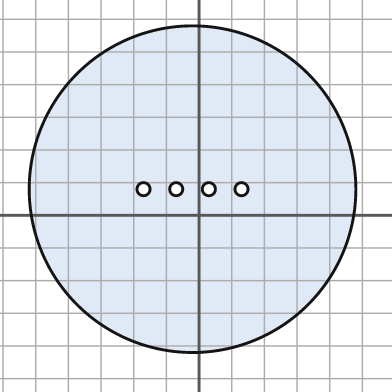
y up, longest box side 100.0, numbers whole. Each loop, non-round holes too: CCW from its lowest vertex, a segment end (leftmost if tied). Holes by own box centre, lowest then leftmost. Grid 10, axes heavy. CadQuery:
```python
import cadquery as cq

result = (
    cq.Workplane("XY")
    .moveTo(-2.0, 8.0)
    .circle(50.0)
    .moveTo(-17.0, 8.0)
    .circle(2.0)
    .moveTo(-7.0, 8.0)
    .circle(2.0)
    .moveTo(3.0, 8.0)
    .circle(2.0)
    .moveTo(13.0, 8.0)
    .circle(2.0)
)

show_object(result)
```